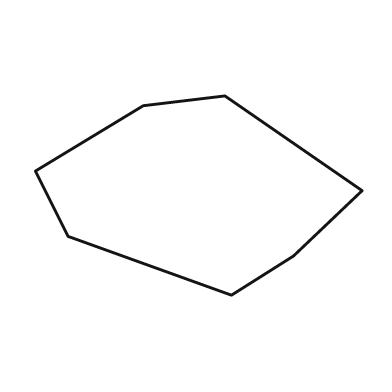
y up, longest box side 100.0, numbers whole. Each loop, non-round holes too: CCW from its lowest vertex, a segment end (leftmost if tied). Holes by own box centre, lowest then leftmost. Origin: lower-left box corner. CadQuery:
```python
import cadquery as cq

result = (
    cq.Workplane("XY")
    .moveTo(60.0, 0.0)
    .lineTo(79.0, 12.0)
    .lineTo(100.0, 32.0)
    .lineTo(58.0, 61.0)
    .lineTo(33.0, 58.0)
    .lineTo(0.0, 38.0)
    .lineTo(10.0, 18.0)
    .close()
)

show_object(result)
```